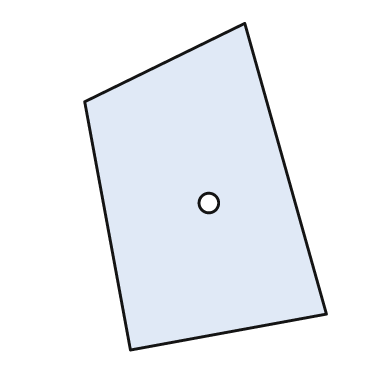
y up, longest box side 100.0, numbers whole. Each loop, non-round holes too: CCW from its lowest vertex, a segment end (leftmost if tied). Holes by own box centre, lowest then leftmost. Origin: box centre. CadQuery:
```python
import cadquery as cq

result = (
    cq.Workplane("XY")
    .moveTo(-23.0, -50.0)
    .lineTo(37.0, -39.0)
    .lineTo(12.0, 50.0)
    .lineTo(-37.0, 26.0)
    .close()
    .moveTo(1.0, -5.0)
    .circle(3.0)
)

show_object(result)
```